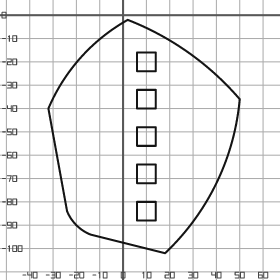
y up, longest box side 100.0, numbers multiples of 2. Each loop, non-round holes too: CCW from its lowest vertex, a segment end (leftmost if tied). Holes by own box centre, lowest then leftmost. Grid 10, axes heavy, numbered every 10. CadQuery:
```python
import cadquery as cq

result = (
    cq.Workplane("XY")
    .moveTo(18.0, -102.0)
    .threePointArc((40.0, -72.0), (50.0, -36.0))
    .threePointArc((28.0, -16.0), (2.0, -2.0))
    .threePointArc((-18.0, -18.0), (-32.0, -40.0))
    .lineTo(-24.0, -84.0)
    .threePointArc((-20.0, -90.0), (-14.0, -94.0))
    .close()
    .moveTo(6.0, -88.0)
    .lineTo(14.0, -88.0)
    .lineTo(14.0, -80.0)
    .lineTo(6.0, -80.0)
    .close()
    .moveTo(6.0, -72.0)
    .lineTo(14.0, -72.0)
    .lineTo(14.0, -64.0)
    .lineTo(6.0, -64.0)
    .close()
    .moveTo(6.0, -56.0)
    .lineTo(14.0, -56.0)
    .lineTo(14.0, -48.0)
    .lineTo(6.0, -48.0)
    .close()
    .moveTo(6.0, -40.0)
    .lineTo(14.0, -40.0)
    .lineTo(14.0, -32.0)
    .lineTo(6.0, -32.0)
    .close()
    .moveTo(6.0, -24.0)
    .lineTo(14.0, -24.0)
    .lineTo(14.0, -16.0)
    .lineTo(6.0, -16.0)
    .close()
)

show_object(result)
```